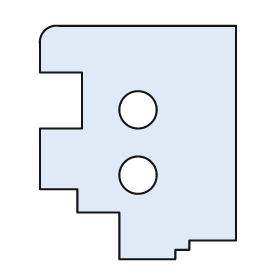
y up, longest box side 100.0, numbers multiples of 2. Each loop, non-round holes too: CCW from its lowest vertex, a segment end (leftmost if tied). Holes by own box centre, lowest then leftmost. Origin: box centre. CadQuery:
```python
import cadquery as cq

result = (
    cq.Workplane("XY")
    .moveTo(-8.0, -50.0)
    .lineTo(16.0, -50.0)
    .lineTo(16.0, -46.0)
    .lineTo(22.0, -46.0)
    .lineTo(22.0, -42.0)
    .lineTo(42.0, -42.0)
    .lineTo(42.0, 50.0)
    .lineTo(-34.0, 50.0)
    .threePointArc((-40.0, 48.0), (-42.0, 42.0))
    .lineTo(-42.0, 30.0)
    .lineTo(-24.0, 30.0)
    .lineTo(-24.0, 6.0)
    .lineTo(-42.0, 6.0)
    .lineTo(-42.0, -20.0)
    .lineTo(-26.0, -20.0)
    .lineTo(-26.0, -30.0)
    .lineTo(-8.0, -30.0)
    .close()
    .moveTo(0.0, -14.0)
    .circle(8.0)
    .moveTo(0.0, 14.0)
    .circle(8.0)
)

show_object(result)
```